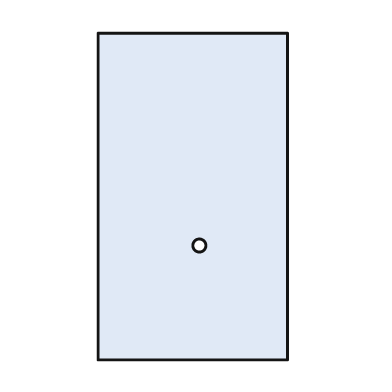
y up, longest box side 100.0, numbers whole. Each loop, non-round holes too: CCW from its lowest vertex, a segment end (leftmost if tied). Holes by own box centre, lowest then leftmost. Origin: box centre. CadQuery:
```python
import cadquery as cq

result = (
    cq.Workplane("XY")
    .moveTo(-29.0, -50.0)
    .lineTo(29.0, -50.0)
    .lineTo(29.0, 50.0)
    .lineTo(-29.0, 50.0)
    .close()
    .moveTo(2.0, -15.0)
    .circle(2.0)
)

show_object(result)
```